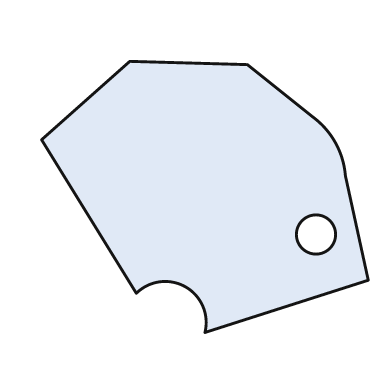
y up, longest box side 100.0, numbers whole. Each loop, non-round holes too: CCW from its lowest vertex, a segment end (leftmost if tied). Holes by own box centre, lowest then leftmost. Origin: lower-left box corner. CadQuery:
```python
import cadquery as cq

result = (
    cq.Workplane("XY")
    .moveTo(50.0, 0.0)
    .lineTo(100.0, 16.0)
    .lineTo(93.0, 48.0)
    .threePointArc((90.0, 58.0), (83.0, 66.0))
    .lineTo(63.0, 82.0)
    .lineTo(27.0, 83.0)
    .lineTo(0.0, 59.0)
    .lineTo(29.0, 12.0)
    .threePointArc((44.0, 14.0), (50.0, 0.0))
    .close()
    .moveTo(84.0, 30.0)
    .circle(6.0)
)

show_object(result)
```